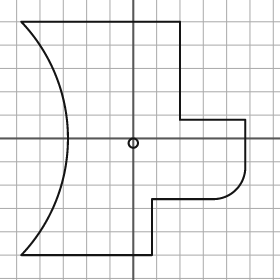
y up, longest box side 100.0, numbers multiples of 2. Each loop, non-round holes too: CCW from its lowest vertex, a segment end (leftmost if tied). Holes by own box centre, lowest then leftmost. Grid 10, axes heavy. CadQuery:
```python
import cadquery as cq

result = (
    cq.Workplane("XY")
    .moveTo(-48.0, -50.0)
    .lineTo(8.0, -50.0)
    .lineTo(8.0, -26.0)
    .lineTo(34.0, -26.0)
    .threePointArc((44.0, -22.0), (48.0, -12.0))
    .lineTo(48.0, 8.0)
    .lineTo(20.0, 8.0)
    .lineTo(20.0, 50.0)
    .lineTo(-48.0, 50.0)
    .threePointArc((-28.0, 0.0), (-48.0, -50.0))
    .close()
    .moveTo(0.0, -2.0)
    .circle(2.0)
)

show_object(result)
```